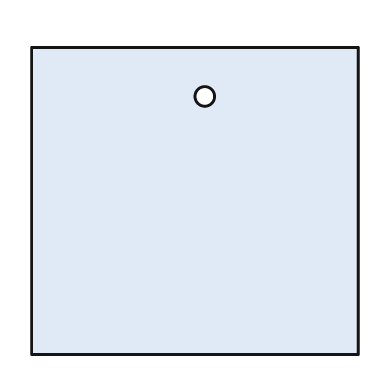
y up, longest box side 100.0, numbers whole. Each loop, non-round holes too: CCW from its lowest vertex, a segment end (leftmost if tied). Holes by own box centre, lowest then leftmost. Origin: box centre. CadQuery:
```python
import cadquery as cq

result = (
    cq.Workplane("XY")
    .moveTo(-50.0, -47.0)
    .lineTo(50.0, -47.0)
    .lineTo(50.0, 47.0)
    .lineTo(-50.0, 47.0)
    .close()
    .moveTo(3.0, 32.0)
    .circle(3.0)
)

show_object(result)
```